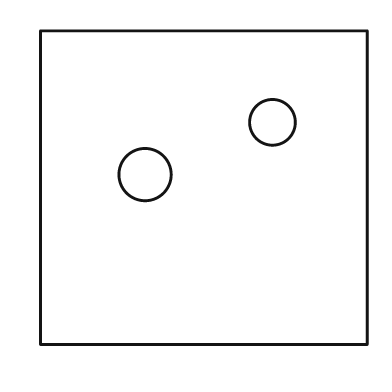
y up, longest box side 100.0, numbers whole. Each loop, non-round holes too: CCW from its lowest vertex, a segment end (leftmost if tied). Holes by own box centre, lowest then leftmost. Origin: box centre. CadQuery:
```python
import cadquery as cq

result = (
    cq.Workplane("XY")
    .moveTo(-50.0, -48.0)
    .lineTo(50.0, -48.0)
    .lineTo(50.0, 48.0)
    .lineTo(-50.0, 48.0)
    .close()
    .moveTo(-18.0, 4.0)
    .circle(8.0)
    .moveTo(21.0, 20.0)
    .circle(7.0)
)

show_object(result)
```